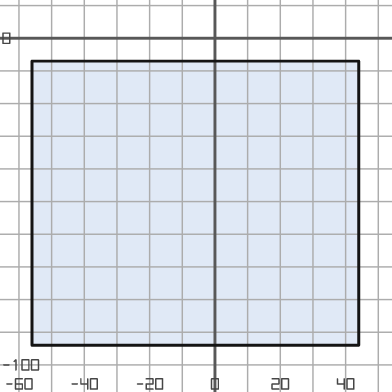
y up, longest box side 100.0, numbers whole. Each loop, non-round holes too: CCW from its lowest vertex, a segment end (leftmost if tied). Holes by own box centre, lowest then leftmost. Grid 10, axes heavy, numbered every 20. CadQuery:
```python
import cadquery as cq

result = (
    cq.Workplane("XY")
    .moveTo(-56.0, -94.0)
    .lineTo(44.0, -94.0)
    .lineTo(44.0, -7.0)
    .lineTo(-56.0, -7.0)
    .close()
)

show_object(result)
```